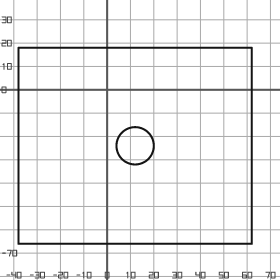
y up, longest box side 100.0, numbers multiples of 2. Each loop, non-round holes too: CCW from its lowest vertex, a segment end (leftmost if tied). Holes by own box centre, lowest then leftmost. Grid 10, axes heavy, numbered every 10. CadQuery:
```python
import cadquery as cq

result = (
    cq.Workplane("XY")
    .moveTo(-38.0, -66.0)
    .lineTo(62.0, -66.0)
    .lineTo(62.0, 18.0)
    .lineTo(-38.0, 18.0)
    .close()
    .moveTo(12.0, -24.0)
    .circle(8.0)
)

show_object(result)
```